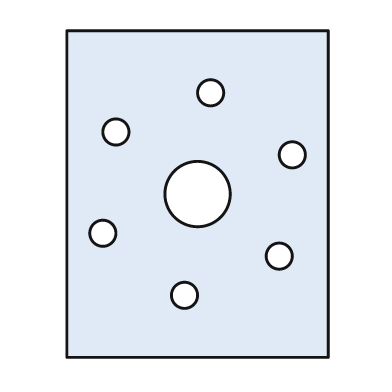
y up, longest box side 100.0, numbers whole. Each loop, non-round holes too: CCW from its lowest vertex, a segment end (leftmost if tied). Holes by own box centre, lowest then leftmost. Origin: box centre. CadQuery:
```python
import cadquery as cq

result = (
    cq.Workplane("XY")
    .moveTo(-40.0, -50.0)
    .lineTo(40.0, -50.0)
    .lineTo(40.0, 50.0)
    .lineTo(-40.0, 50.0)
    .close()
    .moveTo(-4.0, -31.0)
    .circle(4.0)
    .moveTo(25.0, -19.0)
    .circle(4.0)
    .moveTo(-29.0, -12.0)
    .circle(4.0)
    .moveTo(0.0, 0.0)
    .circle(10.0)
    .moveTo(29.0, 12.0)
    .circle(4.0)
    .moveTo(-25.0, 19.0)
    .circle(4.0)
    .moveTo(4.0, 31.0)
    .circle(4.0)
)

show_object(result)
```